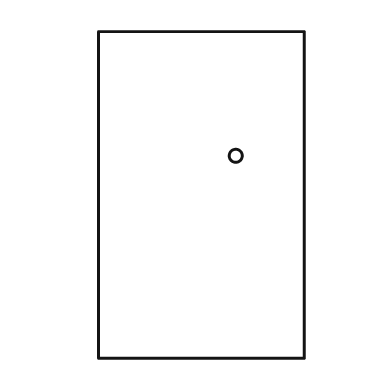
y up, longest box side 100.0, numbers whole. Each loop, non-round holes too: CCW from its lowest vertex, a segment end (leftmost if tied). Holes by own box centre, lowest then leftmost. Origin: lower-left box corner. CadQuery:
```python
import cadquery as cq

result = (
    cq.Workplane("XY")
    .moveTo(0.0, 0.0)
    .lineTo(63.0, 0.0)
    .lineTo(63.0, 100.0)
    .lineTo(0.0, 100.0)
    .close()
    .moveTo(42.0, 62.0)
    .circle(2.0)
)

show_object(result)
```